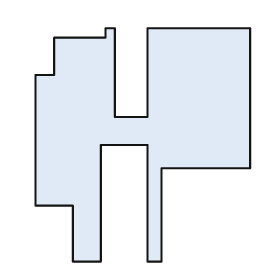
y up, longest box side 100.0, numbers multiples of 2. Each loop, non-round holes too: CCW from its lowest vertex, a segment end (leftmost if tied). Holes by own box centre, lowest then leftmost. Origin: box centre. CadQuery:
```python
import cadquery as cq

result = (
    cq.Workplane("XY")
    .moveTo(-30.0, -50.0)
    .lineTo(-18.0, -50.0)
    .lineTo(-18.0, 0.0)
    .lineTo(2.0, 0.0)
    .lineTo(2.0, -50.0)
    .lineTo(8.0, -50.0)
    .lineTo(8.0, -10.0)
    .lineTo(46.0, -10.0)
    .lineTo(46.0, 50.0)
    .lineTo(2.0, 50.0)
    .lineTo(2.0, 12.0)
    .lineTo(-12.0, 12.0)
    .lineTo(-12.0, 50.0)
    .lineTo(-16.0, 50.0)
    .lineTo(-16.0, 46.0)
    .lineTo(-38.0, 46.0)
    .lineTo(-38.0, 30.0)
    .lineTo(-46.0, 30.0)
    .lineTo(-46.0, -26.0)
    .lineTo(-30.0, -26.0)
    .close()
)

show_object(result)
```